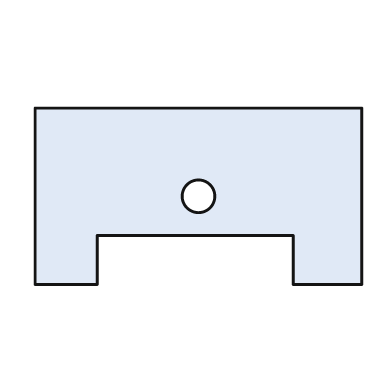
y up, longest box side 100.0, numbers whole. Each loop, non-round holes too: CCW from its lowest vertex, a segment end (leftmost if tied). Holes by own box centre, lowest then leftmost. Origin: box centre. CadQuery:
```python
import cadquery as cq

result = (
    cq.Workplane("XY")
    .moveTo(-50.0, -27.0)
    .lineTo(-31.0, -27.0)
    .lineTo(-31.0, -12.0)
    .lineTo(29.0, -12.0)
    .lineTo(29.0, -27.0)
    .lineTo(50.0, -27.0)
    .lineTo(50.0, 27.0)
    .lineTo(-50.0, 27.0)
    .close()
    .moveTo(0.0, 0.0)
    .circle(5.0)
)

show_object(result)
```